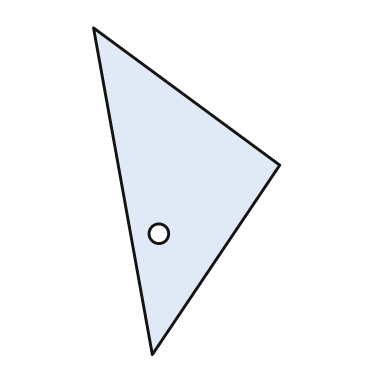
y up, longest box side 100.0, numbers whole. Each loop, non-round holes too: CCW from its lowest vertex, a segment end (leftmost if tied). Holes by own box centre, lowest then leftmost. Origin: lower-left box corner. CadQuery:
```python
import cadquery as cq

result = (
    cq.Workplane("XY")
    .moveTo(18.0, 0.0)
    .lineTo(57.0, 58.0)
    .lineTo(0.0, 100.0)
    .close()
    .moveTo(20.0, 37.0)
    .circle(3.0)
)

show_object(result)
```